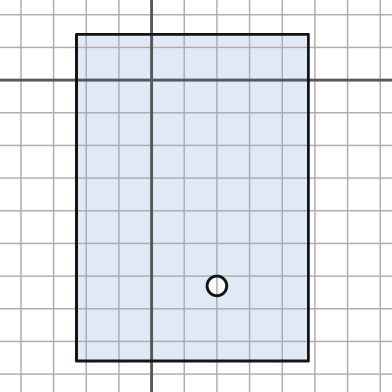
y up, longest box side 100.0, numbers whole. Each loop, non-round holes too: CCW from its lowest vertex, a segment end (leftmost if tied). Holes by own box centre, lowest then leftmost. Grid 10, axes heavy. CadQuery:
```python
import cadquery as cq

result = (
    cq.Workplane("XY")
    .moveTo(-23.0, -86.0)
    .lineTo(48.0, -86.0)
    .lineTo(48.0, 14.0)
    .lineTo(-23.0, 14.0)
    .close()
    .moveTo(20.0, -63.0)
    .circle(3.0)
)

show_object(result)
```